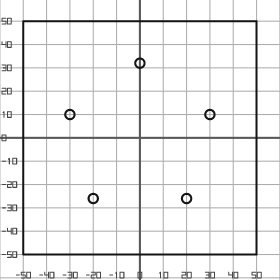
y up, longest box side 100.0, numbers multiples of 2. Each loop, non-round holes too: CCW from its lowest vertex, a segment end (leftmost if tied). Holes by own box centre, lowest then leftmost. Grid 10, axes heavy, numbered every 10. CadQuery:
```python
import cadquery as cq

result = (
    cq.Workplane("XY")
    .moveTo(-50.0, -50.0)
    .lineTo(50.0, -50.0)
    .lineTo(50.0, 50.0)
    .lineTo(-50.0, 50.0)
    .close()
    .moveTo(-20.0, -26.0)
    .circle(2.0)
    .moveTo(20.0, -26.0)
    .circle(2.0)
    .moveTo(-30.0, 10.0)
    .circle(2.0)
    .moveTo(30.0, 10.0)
    .circle(2.0)
    .moveTo(0.0, 32.0)
    .circle(2.0)
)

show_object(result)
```